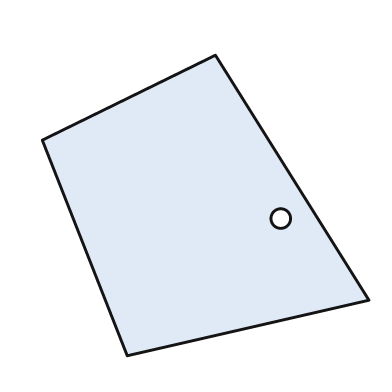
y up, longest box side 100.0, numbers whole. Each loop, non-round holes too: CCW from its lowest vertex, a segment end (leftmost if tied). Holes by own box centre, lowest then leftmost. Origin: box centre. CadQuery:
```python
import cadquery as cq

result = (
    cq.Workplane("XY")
    .moveTo(-24.0, -46.0)
    .lineTo(50.0, -29.0)
    .lineTo(3.0, 46.0)
    .lineTo(-50.0, 20.0)
    .close()
    .moveTo(23.0, -4.0)
    .circle(3.0)
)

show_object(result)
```